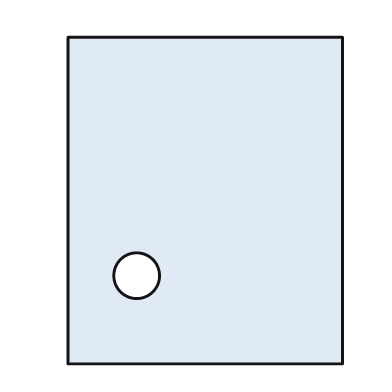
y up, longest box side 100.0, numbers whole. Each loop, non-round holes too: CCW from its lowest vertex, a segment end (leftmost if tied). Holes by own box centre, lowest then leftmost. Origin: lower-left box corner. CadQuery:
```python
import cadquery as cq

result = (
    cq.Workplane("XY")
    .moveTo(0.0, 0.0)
    .lineTo(84.0, 0.0)
    .lineTo(84.0, 100.0)
    .lineTo(0.0, 100.0)
    .close()
    .moveTo(21.0, 27.0)
    .circle(7.0)
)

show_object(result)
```